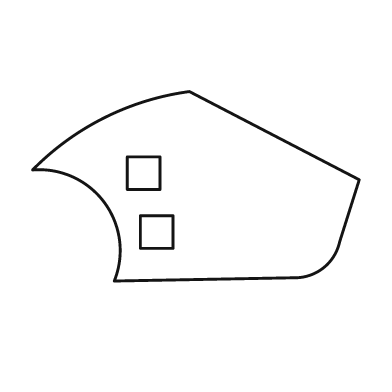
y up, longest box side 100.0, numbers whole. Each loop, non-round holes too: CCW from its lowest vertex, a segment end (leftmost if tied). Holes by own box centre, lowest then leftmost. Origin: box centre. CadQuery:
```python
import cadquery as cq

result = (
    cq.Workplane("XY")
    .moveTo(-25.0, -29.0)
    .lineTo(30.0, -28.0)
    .threePointArc((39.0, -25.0), (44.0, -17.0))
    .lineTo(50.0, 2.0)
    .lineTo(-2.0, 29.0)
    .threePointArc((-28.0, 21.0), (-50.0, 5.0))
    .threePointArc((-28.0, -5.0), (-25.0, -29.0))
    .close()
    .moveTo(-17.0, -19.0)
    .lineTo(-7.0, -19.0)
    .lineTo(-7.0, -9.0)
    .lineTo(-17.0, -9.0)
    .close()
    .moveTo(-21.0, -1.0)
    .lineTo(-11.0, -1.0)
    .lineTo(-11.0, 9.0)
    .lineTo(-21.0, 9.0)
    .close()
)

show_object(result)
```